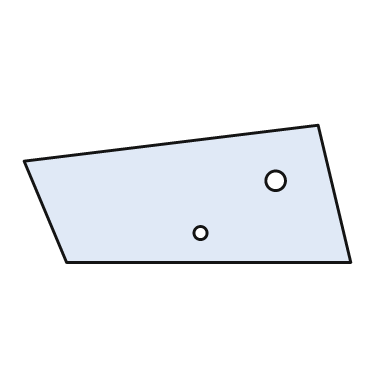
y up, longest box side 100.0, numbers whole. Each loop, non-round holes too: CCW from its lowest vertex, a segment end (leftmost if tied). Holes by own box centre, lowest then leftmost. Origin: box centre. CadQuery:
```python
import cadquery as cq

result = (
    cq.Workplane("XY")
    .moveTo(-37.0, -21.0)
    .lineTo(50.0, -21.0)
    .lineTo(40.0, 21.0)
    .lineTo(-50.0, 10.0)
    .close()
    .moveTo(4.0, -12.0)
    .circle(2.0)
    .moveTo(27.0, 4.0)
    .circle(3.0)
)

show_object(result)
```